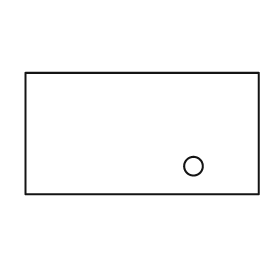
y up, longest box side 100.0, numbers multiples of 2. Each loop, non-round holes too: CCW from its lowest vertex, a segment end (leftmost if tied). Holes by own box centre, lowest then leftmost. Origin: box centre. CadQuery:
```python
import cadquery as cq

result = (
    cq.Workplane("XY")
    .moveTo(-50.0, -26.0)
    .lineTo(50.0, -26.0)
    .lineTo(50.0, 26.0)
    .lineTo(-50.0, 26.0)
    .close()
    .moveTo(22.0, -14.0)
    .circle(4.0)
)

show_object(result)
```